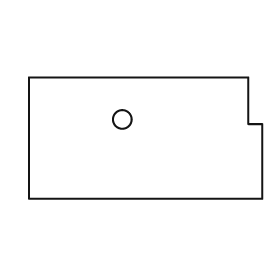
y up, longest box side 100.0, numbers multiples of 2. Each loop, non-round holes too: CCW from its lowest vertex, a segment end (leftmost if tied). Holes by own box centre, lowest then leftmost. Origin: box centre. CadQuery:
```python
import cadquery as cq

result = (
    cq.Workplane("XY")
    .moveTo(-50.0, -26.0)
    .lineTo(50.0, -26.0)
    .lineTo(50.0, 6.0)
    .lineTo(44.0, 6.0)
    .lineTo(44.0, 26.0)
    .lineTo(-50.0, 26.0)
    .close()
    .moveTo(-10.0, 8.0)
    .circle(4.0)
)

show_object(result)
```